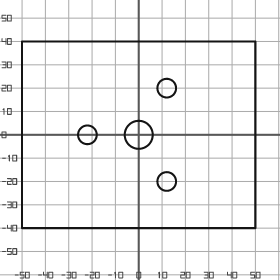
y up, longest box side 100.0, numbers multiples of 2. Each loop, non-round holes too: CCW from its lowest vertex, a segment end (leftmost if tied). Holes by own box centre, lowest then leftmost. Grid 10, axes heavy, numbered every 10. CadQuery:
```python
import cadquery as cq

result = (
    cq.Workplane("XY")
    .moveTo(-50.0, -40.0)
    .lineTo(50.0, -40.0)
    .lineTo(50.0, 40.0)
    .lineTo(-50.0, 40.0)
    .close()
    .moveTo(12.0, -20.0)
    .circle(4.0)
    .moveTo(-22.0, 0.0)
    .circle(4.0)
    .moveTo(0.0, 0.0)
    .circle(6.0)
    .moveTo(12.0, 20.0)
    .circle(4.0)
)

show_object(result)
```